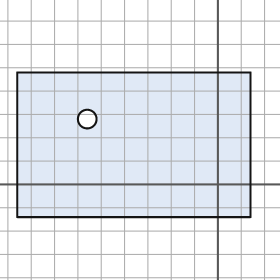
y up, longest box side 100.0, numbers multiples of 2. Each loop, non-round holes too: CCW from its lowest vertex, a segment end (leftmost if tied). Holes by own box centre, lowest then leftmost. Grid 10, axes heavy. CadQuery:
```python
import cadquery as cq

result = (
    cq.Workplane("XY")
    .moveTo(-86.0, -14.0)
    .lineTo(14.0, -14.0)
    .lineTo(14.0, 48.0)
    .lineTo(-86.0, 48.0)
    .close()
    .moveTo(-56.0, 28.0)
    .circle(4.0)
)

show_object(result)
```